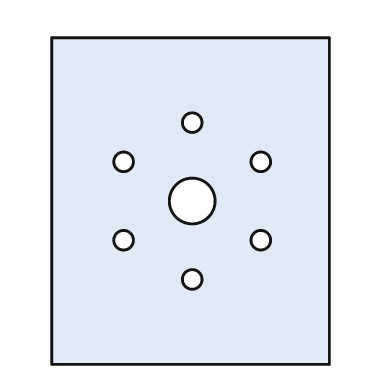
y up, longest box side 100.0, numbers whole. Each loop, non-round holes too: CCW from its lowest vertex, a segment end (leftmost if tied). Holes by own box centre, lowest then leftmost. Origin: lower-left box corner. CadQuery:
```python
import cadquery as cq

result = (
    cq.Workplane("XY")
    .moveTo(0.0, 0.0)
    .lineTo(85.0, 0.0)
    .lineTo(85.0, 100.0)
    .lineTo(0.0, 100.0)
    .close()
    .moveTo(43.0, 26.0)
    .circle(3.0)
    .moveTo(22.0, 38.0)
    .circle(3.0)
    .moveTo(64.0, 38.0)
    .circle(3.0)
    .moveTo(43.0, 50.0)
    .circle(7.0)
    .moveTo(22.0, 62.0)
    .circle(3.0)
    .moveTo(64.0, 62.0)
    .circle(3.0)
    .moveTo(43.0, 74.0)
    .circle(3.0)
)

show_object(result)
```